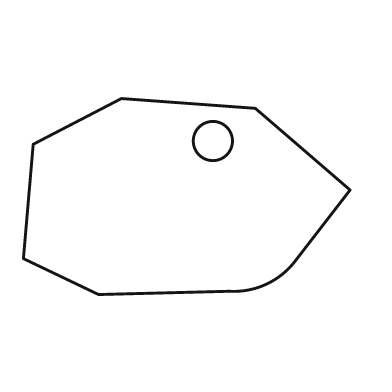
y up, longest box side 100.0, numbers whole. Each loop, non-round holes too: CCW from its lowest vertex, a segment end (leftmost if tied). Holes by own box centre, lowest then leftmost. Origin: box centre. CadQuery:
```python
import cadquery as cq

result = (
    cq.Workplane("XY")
    .moveTo(-27.0, -30.0)
    .lineTo(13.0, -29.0)
    .threePointArc((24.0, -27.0), (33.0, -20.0))
    .lineTo(50.0, 2.0)
    .lineTo(21.0, 27.0)
    .lineTo(-20.0, 30.0)
    .lineTo(-47.0, 16.0)
    .lineTo(-50.0, -19.0)
    .close()
    .moveTo(8.0, 17.0)
    .circle(6.0)
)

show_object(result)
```